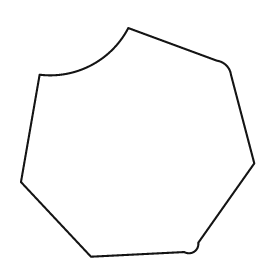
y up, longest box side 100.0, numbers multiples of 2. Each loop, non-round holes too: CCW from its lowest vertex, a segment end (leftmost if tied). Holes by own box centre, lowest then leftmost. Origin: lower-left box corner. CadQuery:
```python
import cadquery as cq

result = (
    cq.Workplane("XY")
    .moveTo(30.0, 0.0)
    .lineTo(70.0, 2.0)
    .threePointArc((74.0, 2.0), (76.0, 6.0))
    .lineTo(100.0, 40.0)
    .lineTo(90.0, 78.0)
    .threePointArc((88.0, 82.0), (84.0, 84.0))
    .lineTo(46.0, 98.0)
    .threePointArc((30.0, 82.0), (8.0, 78.0))
    .lineTo(0.0, 32.0)
    .close()
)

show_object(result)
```